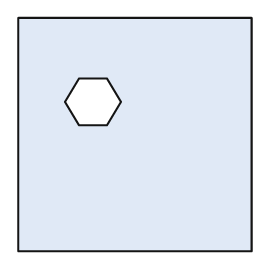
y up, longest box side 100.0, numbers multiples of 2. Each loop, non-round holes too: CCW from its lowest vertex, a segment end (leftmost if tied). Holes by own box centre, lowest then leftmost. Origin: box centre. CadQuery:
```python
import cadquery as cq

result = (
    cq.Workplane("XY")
    .moveTo(-50.0, -50.0)
    .lineTo(50.0, -50.0)
    .lineTo(50.0, 50.0)
    .lineTo(-50.0, 50.0)
    .close()
    .moveTo(-24.0, 4.0)
    .lineTo(-12.0, 4.0)
    .lineTo(-6.0, 14.0)
    .lineTo(-12.0, 24.0)
    .lineTo(-24.0, 24.0)
    .lineTo(-30.0, 14.0)
    .close()
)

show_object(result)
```